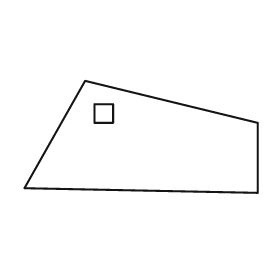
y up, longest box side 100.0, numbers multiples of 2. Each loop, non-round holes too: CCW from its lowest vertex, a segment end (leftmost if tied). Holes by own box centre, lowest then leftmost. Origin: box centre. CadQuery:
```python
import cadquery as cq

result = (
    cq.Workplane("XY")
    .moveTo(50.0, -24.0)
    .lineTo(50.0, 6.0)
    .lineTo(-24.0, 24.0)
    .lineTo(-50.0, -22.0)
    .close()
    .moveTo(-20.0, 6.0)
    .lineTo(-12.0, 6.0)
    .lineTo(-12.0, 14.0)
    .lineTo(-20.0, 14.0)
    .close()
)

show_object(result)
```